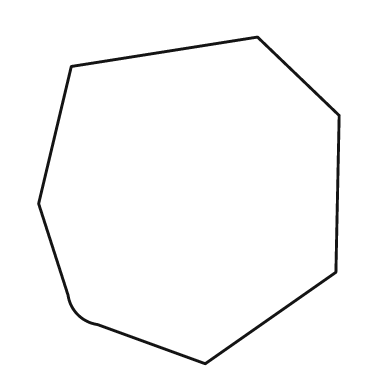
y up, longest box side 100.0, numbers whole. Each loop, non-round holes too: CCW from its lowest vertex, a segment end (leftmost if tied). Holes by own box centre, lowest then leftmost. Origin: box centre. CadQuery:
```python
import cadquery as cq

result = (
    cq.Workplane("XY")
    .moveTo(5.0, -50.0)
    .lineTo(45.0, -22.0)
    .lineTo(46.0, 26.0)
    .lineTo(21.0, 50.0)
    .lineTo(-36.0, 41.0)
    .lineTo(-46.0, -1.0)
    .lineTo(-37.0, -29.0)
    .threePointArc((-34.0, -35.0), (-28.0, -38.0))
    .close()
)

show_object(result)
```